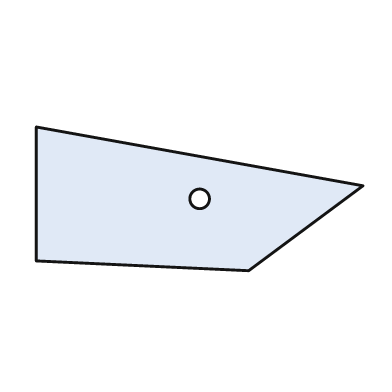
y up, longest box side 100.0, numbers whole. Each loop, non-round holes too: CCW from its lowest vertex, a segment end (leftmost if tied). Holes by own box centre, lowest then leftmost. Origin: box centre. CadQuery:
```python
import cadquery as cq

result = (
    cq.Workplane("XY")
    .moveTo(15.0, -22.0)
    .lineTo(50.0, 4.0)
    .lineTo(-50.0, 22.0)
    .lineTo(-50.0, -19.0)
    .close()
    .moveTo(0.0, 0.0)
    .circle(3.0)
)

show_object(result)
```